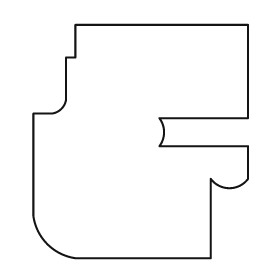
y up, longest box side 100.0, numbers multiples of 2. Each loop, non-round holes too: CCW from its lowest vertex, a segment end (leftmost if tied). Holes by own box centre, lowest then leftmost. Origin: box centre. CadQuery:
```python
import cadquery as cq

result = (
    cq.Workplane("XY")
    .moveTo(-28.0, -50.0)
    .lineTo(30.0, -50.0)
    .lineTo(30.0, -16.0)
    .threePointArc((38.0, -20.0), (46.0, -16.0))
    .lineTo(46.0, -2.0)
    .lineTo(8.0, -2.0)
    .threePointArc((10.0, 4.0), (8.0, 10.0))
    .lineTo(46.0, 10.0)
    .lineTo(46.0, 50.0)
    .lineTo(-28.0, 50.0)
    .lineTo(-28.0, 36.0)
    .lineTo(-32.0, 36.0)
    .lineTo(-32.0, 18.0)
    .threePointArc((-34.0, 14.0), (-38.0, 12.0))
    .lineTo(-46.0, 12.0)
    .lineTo(-46.0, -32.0)
    .threePointArc((-40.0, -44.0), (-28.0, -50.0))
    .close()
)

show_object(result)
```